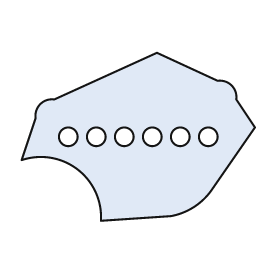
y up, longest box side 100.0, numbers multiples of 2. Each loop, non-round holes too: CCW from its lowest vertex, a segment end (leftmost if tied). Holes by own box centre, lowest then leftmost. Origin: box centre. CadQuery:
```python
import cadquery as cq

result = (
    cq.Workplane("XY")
    .moveTo(-16.0, -36.0)
    .lineTo(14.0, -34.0)
    .threePointArc((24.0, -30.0), (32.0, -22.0))
    .lineTo(50.0, 4.0)
    .lineTo(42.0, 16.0)
    .threePointArc((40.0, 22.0), (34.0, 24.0))
    .lineTo(8.0, 36.0)
    .lineTo(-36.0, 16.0)
    .threePointArc((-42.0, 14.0), (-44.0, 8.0))
    .lineTo(-50.0, -10.0)
    .threePointArc((-26.0, -14.0), (-16.0, -36.0))
    .close()
    .moveTo(-30.0, 0.0)
    .circle(4.0)
    .moveTo(-18.0, 0.0)
    .circle(4.0)
    .moveTo(-6.0, 0.0)
    .circle(4.0)
    .moveTo(6.0, 0.0)
    .circle(4.0)
    .moveTo(18.0, 0.0)
    .circle(4.0)
    .moveTo(30.0, 0.0)
    .circle(4.0)
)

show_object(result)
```